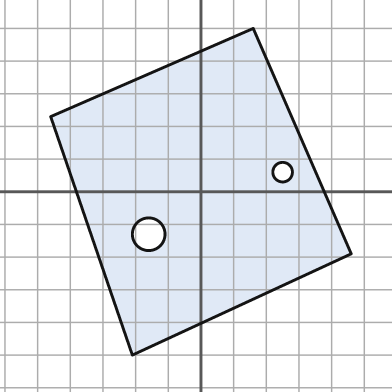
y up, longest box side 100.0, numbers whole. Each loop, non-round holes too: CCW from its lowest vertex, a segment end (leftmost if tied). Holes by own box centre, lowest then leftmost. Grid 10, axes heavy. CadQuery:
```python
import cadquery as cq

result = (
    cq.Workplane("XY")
    .moveTo(-21.0, -50.0)
    .lineTo(46.0, -19.0)
    .lineTo(16.0, 50.0)
    .lineTo(-46.0, 23.0)
    .close()
    .moveTo(-16.0, -13.0)
    .circle(5.0)
    .moveTo(25.0, 6.0)
    .circle(3.0)
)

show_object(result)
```